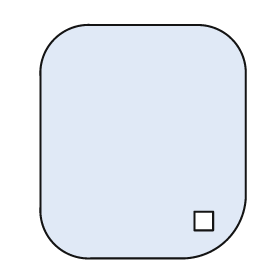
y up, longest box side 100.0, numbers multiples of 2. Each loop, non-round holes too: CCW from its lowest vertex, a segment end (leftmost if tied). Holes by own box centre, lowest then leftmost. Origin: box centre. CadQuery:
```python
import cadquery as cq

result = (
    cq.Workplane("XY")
    .moveTo(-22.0, -50.0)
    .lineTo(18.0, -50.0)
    .threePointArc((36.0, -42.0), (44.0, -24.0))
    .lineTo(44.0, 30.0)
    .threePointArc((38.0, 44.0), (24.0, 50.0))
    .lineTo(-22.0, 50.0)
    .threePointArc((-38.0, 44.0), (-44.0, 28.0))
    .lineTo(-44.0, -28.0)
    .threePointArc((-38.0, -44.0), (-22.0, -50.0))
    .close()
    .moveTo(22.0, -38.0)
    .lineTo(30.0, -38.0)
    .lineTo(30.0, -30.0)
    .lineTo(22.0, -30.0)
    .close()
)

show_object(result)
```